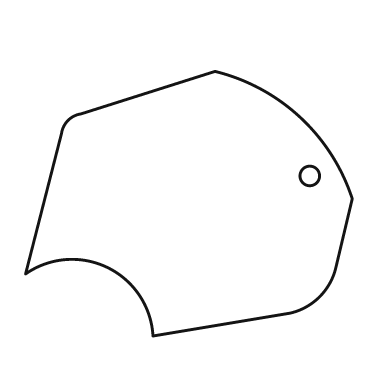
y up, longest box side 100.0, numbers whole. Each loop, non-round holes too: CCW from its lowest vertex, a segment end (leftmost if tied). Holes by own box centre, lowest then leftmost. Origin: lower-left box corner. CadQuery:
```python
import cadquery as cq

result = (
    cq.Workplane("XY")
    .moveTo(39.0, 0.0)
    .lineTo(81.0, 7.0)
    .threePointArc((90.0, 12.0), (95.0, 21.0))
    .lineTo(100.0, 42.0)
    .threePointArc((84.0, 67.0), (58.0, 81.0))
    .lineTo(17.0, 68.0)
    .threePointArc((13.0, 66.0), (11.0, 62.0))
    .lineTo(0.0, 19.0)
    .threePointArc((25.0, 21.0), (39.0, 0.0))
    .close()
    .moveTo(87.0, 49.0)
    .circle(3.0)
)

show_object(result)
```